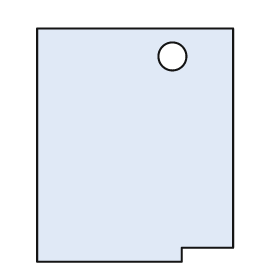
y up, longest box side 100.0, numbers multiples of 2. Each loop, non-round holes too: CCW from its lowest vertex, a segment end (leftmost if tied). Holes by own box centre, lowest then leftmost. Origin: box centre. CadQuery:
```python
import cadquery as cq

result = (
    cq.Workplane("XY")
    .moveTo(-42.0, -50.0)
    .lineTo(20.0, -50.0)
    .lineTo(20.0, -44.0)
    .lineTo(42.0, -44.0)
    .lineTo(42.0, 50.0)
    .lineTo(-42.0, 50.0)
    .close()
    .moveTo(16.0, 38.0)
    .circle(6.0)
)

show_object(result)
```